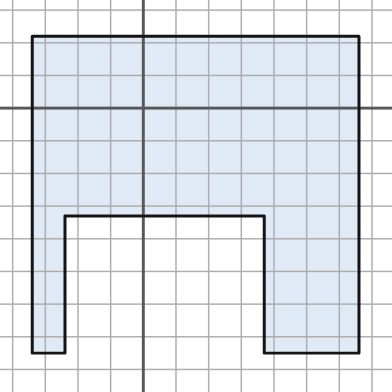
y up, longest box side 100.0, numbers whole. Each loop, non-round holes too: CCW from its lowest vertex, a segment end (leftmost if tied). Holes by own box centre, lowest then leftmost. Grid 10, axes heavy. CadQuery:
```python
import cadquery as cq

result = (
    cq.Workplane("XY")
    .moveTo(-34.0, -75.0)
    .lineTo(-24.0, -75.0)
    .lineTo(-24.0, -33.0)
    .lineTo(37.0, -33.0)
    .lineTo(37.0, -75.0)
    .lineTo(66.0, -75.0)
    .lineTo(66.0, 22.0)
    .lineTo(-34.0, 22.0)
    .close()
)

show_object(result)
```